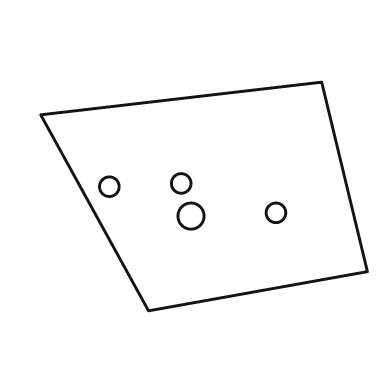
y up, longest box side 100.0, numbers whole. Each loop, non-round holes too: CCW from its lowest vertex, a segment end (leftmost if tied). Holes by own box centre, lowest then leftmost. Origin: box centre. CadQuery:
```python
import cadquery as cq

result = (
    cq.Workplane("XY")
    .moveTo(-17.0, -35.0)
    .lineTo(50.0, -23.0)
    .lineTo(36.0, 35.0)
    .lineTo(-50.0, 25.0)
    .close()
    .moveTo(-4.0, -6.0)
    .circle(4.0)
    .moveTo(22.0, -5.0)
    .circle(3.0)
    .moveTo(-29.0, 3.0)
    .circle(3.0)
    .moveTo(-7.0, 4.0)
    .circle(3.0)
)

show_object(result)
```